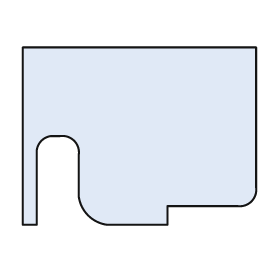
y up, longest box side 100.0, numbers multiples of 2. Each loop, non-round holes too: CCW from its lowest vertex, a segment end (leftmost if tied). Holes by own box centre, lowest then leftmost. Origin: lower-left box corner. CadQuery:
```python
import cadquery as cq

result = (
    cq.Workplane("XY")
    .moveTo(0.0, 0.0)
    .lineTo(6.0, 0.0)
    .lineTo(6.0, 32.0)
    .threePointArc((8.0, 36.0), (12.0, 38.0))
    .lineTo(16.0, 38.0)
    .threePointArc((22.0, 36.0), (24.0, 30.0))
    .lineTo(24.0, 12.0)
    .threePointArc((28.0, 4.0), (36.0, 0.0))
    .lineTo(62.0, 0.0)
    .lineTo(62.0, 8.0)
    .lineTo(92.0, 8.0)
    .threePointArc((98.0, 10.0), (100.0, 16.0))
    .lineTo(100.0, 76.0)
    .lineTo(0.0, 76.0)
    .close()
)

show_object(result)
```